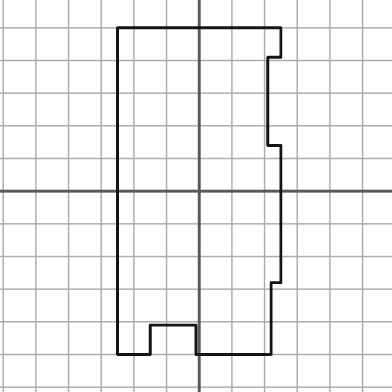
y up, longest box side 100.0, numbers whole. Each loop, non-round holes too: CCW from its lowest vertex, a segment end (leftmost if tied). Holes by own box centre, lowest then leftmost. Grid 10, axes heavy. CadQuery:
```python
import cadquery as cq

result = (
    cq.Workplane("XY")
    .moveTo(-25.0, -50.0)
    .lineTo(-15.0, -50.0)
    .lineTo(-15.0, -41.0)
    .lineTo(-1.0, -41.0)
    .lineTo(-1.0, -50.0)
    .lineTo(22.0, -50.0)
    .lineTo(22.0, -28.0)
    .lineTo(25.0, -28.0)
    .lineTo(25.0, 14.0)
    .lineTo(21.0, 14.0)
    .lineTo(21.0, 41.0)
    .lineTo(25.0, 41.0)
    .lineTo(25.0, 50.0)
    .lineTo(-25.0, 50.0)
    .close()
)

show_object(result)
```